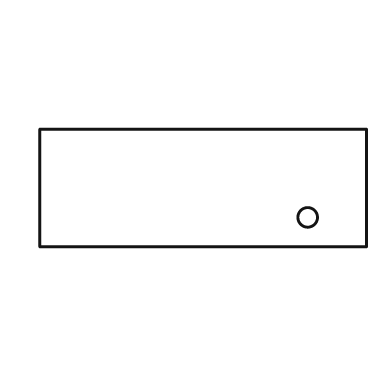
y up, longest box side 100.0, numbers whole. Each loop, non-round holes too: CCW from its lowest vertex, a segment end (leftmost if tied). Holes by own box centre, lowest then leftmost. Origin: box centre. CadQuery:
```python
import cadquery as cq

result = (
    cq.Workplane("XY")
    .moveTo(-50.0, -18.0)
    .lineTo(50.0, -18.0)
    .lineTo(50.0, 18.0)
    .lineTo(-50.0, 18.0)
    .close()
    .moveTo(32.0, -9.0)
    .circle(3.0)
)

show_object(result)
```